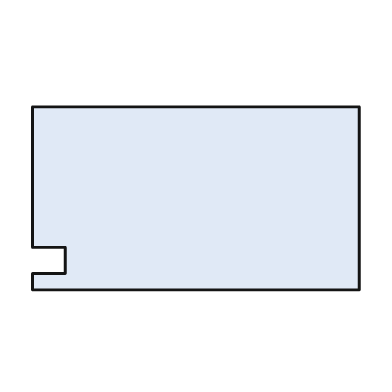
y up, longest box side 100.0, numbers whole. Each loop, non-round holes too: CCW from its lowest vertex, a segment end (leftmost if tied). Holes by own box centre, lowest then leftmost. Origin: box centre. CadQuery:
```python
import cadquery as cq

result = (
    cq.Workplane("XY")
    .moveTo(-50.0, -28.0)
    .lineTo(50.0, -28.0)
    .lineTo(50.0, 28.0)
    .lineTo(-50.0, 28.0)
    .lineTo(-50.0, -15.0)
    .lineTo(-40.0, -15.0)
    .lineTo(-40.0, -23.0)
    .lineTo(-50.0, -23.0)
    .close()
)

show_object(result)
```